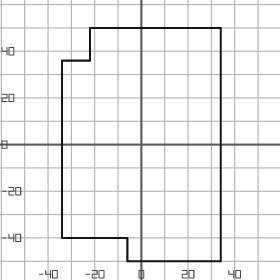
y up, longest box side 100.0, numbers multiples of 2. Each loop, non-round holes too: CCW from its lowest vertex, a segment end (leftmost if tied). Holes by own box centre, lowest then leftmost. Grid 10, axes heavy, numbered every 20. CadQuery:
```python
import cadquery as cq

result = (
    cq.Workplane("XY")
    .moveTo(-6.0, -50.0)
    .lineTo(34.0, -50.0)
    .lineTo(34.0, 50.0)
    .lineTo(-22.0, 50.0)
    .lineTo(-22.0, 36.0)
    .lineTo(-34.0, 36.0)
    .lineTo(-34.0, -40.0)
    .lineTo(-6.0, -40.0)
    .close()
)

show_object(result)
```